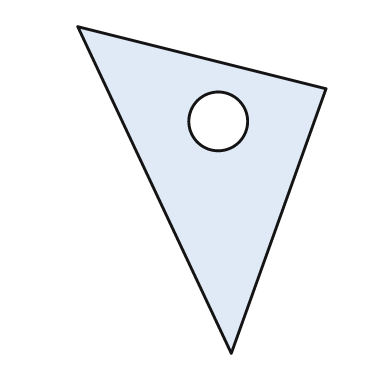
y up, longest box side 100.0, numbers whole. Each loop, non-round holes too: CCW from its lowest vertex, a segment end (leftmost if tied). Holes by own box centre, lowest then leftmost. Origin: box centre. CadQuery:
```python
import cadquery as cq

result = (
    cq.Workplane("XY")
    .moveTo(9.0, -50.0)
    .lineTo(38.0, 31.0)
    .lineTo(-38.0, 50.0)
    .close()
    .moveTo(5.0, 21.0)
    .circle(9.0)
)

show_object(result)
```